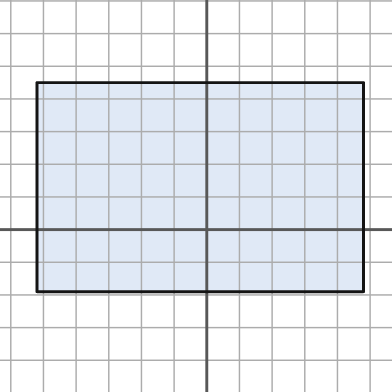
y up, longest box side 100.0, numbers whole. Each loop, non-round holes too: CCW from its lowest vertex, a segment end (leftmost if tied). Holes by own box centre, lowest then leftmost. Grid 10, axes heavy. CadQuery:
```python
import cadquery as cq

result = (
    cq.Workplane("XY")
    .moveTo(-52.0, -19.0)
    .lineTo(48.0, -19.0)
    .lineTo(48.0, 45.0)
    .lineTo(-52.0, 45.0)
    .close()
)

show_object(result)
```